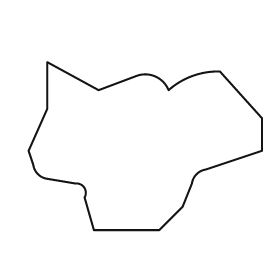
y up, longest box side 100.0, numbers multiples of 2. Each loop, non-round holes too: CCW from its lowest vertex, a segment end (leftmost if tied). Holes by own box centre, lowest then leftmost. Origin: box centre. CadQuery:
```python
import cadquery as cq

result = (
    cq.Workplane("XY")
    .moveTo(-22.0, -36.0)
    .lineTo(6.0, -36.0)
    .lineTo(16.0, -26.0)
    .lineTo(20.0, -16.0)
    .threePointArc((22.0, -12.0), (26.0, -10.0))
    .lineTo(50.0, -2.0)
    .lineTo(50.0, 12.0)
    .lineTo(32.0, 32.0)
    .threePointArc((20.0, 30.0), (10.0, 24.0))
    .threePointArc((4.0, 30.0), (-4.0, 30.0))
    .lineTo(-20.0, 24.0)
    .lineTo(-42.0, 36.0)
    .lineTo(-42.0, 16.0)
    .lineTo(-50.0, -2.0)
    .lineTo(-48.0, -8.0)
    .threePointArc((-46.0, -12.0), (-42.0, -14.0))
    .lineTo(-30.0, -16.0)
    .threePointArc((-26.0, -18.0), (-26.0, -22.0))
    .close()
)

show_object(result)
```